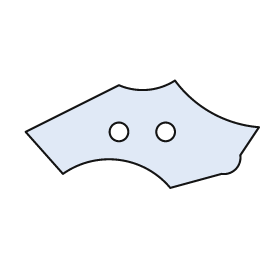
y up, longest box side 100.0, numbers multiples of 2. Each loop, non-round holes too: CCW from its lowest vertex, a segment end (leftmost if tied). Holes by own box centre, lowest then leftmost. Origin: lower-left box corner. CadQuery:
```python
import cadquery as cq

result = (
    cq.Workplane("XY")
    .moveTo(62.0, 0.0)
    .lineTo(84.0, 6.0)
    .threePointArc((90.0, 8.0), (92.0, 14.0))
    .lineTo(100.0, 26.0)
    .threePointArc((80.0, 32.0), (64.0, 46.0))
    .threePointArc((52.0, 42.0), (40.0, 44.0))
    .lineTo(0.0, 24.0)
    .lineTo(16.0, 6.0)
    .threePointArc((40.0, 12.0), (62.0, 0.0))
    .close()
    .moveTo(40.0, 24.0)
    .circle(4.0)
    .moveTo(60.0, 24.0)
    .circle(4.0)
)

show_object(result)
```